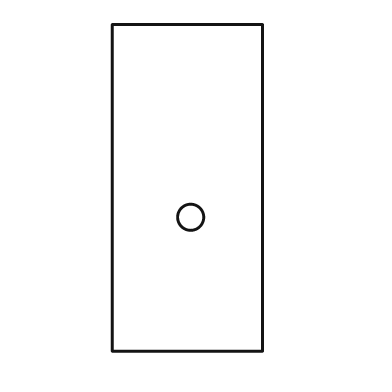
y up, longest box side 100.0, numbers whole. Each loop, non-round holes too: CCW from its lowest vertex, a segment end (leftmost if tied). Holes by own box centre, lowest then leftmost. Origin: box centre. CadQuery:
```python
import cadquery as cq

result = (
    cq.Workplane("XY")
    .moveTo(-23.0, -50.0)
    .lineTo(23.0, -50.0)
    .lineTo(23.0, 50.0)
    .lineTo(-23.0, 50.0)
    .close()
    .moveTo(1.0, -9.0)
    .circle(4.0)
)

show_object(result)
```